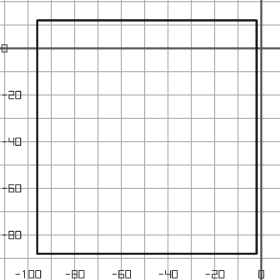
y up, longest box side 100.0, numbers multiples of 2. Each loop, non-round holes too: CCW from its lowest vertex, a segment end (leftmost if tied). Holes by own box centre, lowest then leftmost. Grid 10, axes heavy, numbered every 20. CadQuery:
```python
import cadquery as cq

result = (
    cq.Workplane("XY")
    .moveTo(-96.0, -88.0)
    .lineTo(-2.0, -88.0)
    .lineTo(-2.0, 12.0)
    .lineTo(-96.0, 12.0)
    .close()
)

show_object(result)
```